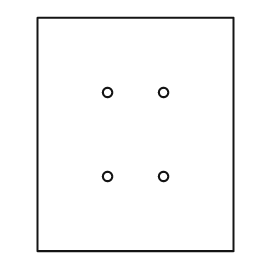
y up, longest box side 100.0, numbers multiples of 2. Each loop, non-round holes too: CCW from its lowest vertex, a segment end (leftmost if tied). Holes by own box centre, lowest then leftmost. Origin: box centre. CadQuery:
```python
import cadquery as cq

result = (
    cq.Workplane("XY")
    .moveTo(-42.0, -50.0)
    .lineTo(42.0, -50.0)
    .lineTo(42.0, 50.0)
    .lineTo(-42.0, 50.0)
    .close()
    .moveTo(-12.0, -18.0)
    .circle(2.0)
    .moveTo(12.0, -18.0)
    .circle(2.0)
    .moveTo(-12.0, 18.0)
    .circle(2.0)
    .moveTo(12.0, 18.0)
    .circle(2.0)
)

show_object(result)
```